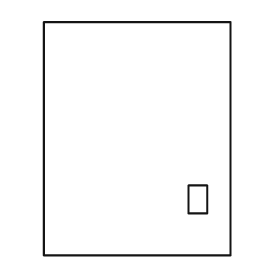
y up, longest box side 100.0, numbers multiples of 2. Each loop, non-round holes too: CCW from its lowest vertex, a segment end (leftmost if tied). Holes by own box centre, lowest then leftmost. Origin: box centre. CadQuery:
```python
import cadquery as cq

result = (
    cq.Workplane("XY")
    .moveTo(-40.0, -50.0)
    .lineTo(40.0, -50.0)
    .lineTo(40.0, 50.0)
    .lineTo(-40.0, 50.0)
    .close()
    .moveTo(22.0, -32.0)
    .lineTo(30.0, -32.0)
    .lineTo(30.0, -20.0)
    .lineTo(22.0, -20.0)
    .close()
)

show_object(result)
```